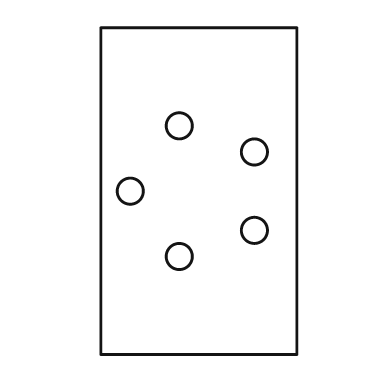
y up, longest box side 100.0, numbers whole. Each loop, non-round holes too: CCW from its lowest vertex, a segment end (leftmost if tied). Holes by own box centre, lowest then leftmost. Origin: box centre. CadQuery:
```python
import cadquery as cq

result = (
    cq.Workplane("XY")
    .moveTo(-30.0, -50.0)
    .lineTo(30.0, -50.0)
    .lineTo(30.0, 50.0)
    .lineTo(-30.0, 50.0)
    .close()
    .moveTo(-6.0, -20.0)
    .circle(4.0)
    .moveTo(17.0, -12.0)
    .circle(4.0)
    .moveTo(-21.0, 0.0)
    .circle(4.0)
    .moveTo(17.0, 12.0)
    .circle(4.0)
    .moveTo(-6.0, 20.0)
    .circle(4.0)
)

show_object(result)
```